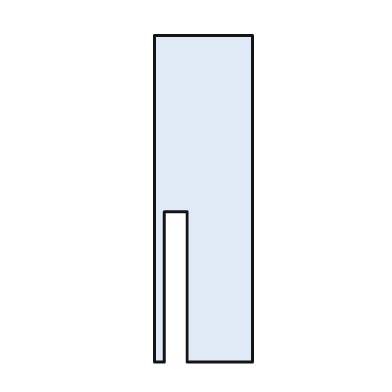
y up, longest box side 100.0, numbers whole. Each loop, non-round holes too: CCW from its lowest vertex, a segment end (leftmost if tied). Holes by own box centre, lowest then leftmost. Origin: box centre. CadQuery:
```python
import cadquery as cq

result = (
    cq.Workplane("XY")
    .moveTo(-15.0, -50.0)
    .lineTo(-12.0, -50.0)
    .lineTo(-12.0, -4.0)
    .lineTo(-5.0, -4.0)
    .lineTo(-5.0, -50.0)
    .lineTo(15.0, -50.0)
    .lineTo(15.0, 50.0)
    .lineTo(-15.0, 50.0)
    .close()
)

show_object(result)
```